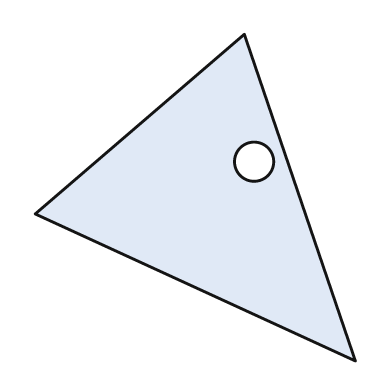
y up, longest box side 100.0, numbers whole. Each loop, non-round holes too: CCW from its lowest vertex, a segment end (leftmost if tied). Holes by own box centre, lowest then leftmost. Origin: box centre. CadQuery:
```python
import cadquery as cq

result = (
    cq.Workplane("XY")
    .moveTo(49.0, -50.0)
    .lineTo(15.0, 50.0)
    .lineTo(-49.0, -5.0)
    .close()
    .moveTo(18.0, 11.0)
    .circle(6.0)
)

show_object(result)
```